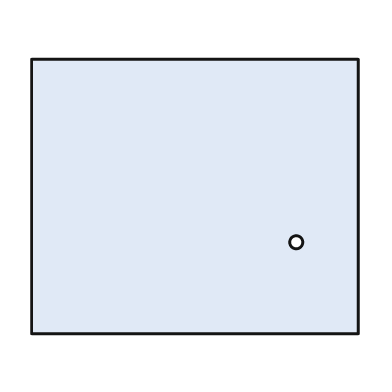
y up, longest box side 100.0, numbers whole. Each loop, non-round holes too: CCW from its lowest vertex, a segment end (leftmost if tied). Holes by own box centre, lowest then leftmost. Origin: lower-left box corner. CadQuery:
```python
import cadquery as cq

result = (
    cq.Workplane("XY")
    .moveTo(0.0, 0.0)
    .lineTo(100.0, 0.0)
    .lineTo(100.0, 84.0)
    .lineTo(0.0, 84.0)
    .close()
    .moveTo(81.0, 28.0)
    .circle(2.0)
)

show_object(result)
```